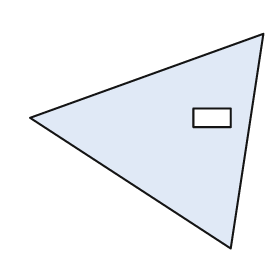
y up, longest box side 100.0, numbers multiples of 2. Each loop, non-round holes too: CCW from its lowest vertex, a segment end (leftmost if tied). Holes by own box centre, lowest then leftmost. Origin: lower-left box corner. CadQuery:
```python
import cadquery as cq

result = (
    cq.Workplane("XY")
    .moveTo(86.0, 0.0)
    .lineTo(100.0, 92.0)
    .lineTo(0.0, 56.0)
    .close()
    .moveTo(70.0, 52.0)
    .lineTo(86.0, 52.0)
    .lineTo(86.0, 60.0)
    .lineTo(70.0, 60.0)
    .close()
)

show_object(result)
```